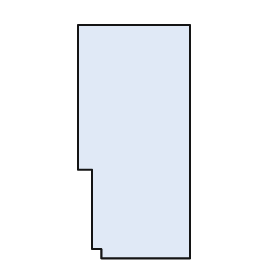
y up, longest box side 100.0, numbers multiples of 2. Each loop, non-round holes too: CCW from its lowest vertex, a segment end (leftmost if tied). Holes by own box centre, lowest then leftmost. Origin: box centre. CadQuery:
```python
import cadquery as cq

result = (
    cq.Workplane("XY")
    .moveTo(-14.0, -50.0)
    .lineTo(24.0, -50.0)
    .lineTo(24.0, 50.0)
    .lineTo(-24.0, 50.0)
    .lineTo(-24.0, -12.0)
    .lineTo(-18.0, -12.0)
    .lineTo(-18.0, -46.0)
    .lineTo(-14.0, -46.0)
    .close()
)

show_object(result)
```